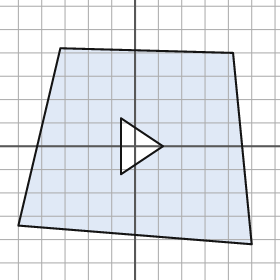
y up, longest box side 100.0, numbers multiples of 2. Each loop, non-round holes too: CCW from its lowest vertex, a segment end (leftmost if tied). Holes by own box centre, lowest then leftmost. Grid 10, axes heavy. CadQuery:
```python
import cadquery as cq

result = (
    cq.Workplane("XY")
    .moveTo(50.0, -42.0)
    .lineTo(42.0, 40.0)
    .lineTo(-32.0, 42.0)
    .lineTo(-50.0, -34.0)
    .close()
    .moveTo(-6.0, -12.0)
    .lineTo(12.0, 0.0)
    .lineTo(-6.0, 12.0)
    .close()
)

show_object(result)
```